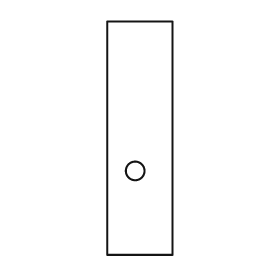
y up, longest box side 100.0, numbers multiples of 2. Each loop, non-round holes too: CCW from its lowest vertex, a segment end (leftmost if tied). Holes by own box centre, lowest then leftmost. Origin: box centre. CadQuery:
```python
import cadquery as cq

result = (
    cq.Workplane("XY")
    .moveTo(-14.0, -50.0)
    .lineTo(14.0, -50.0)
    .lineTo(14.0, 50.0)
    .lineTo(-14.0, 50.0)
    .close()
    .moveTo(-2.0, -14.0)
    .circle(4.0)
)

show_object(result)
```